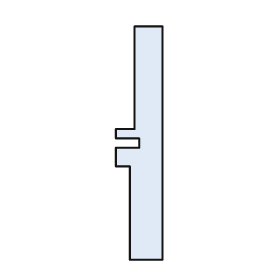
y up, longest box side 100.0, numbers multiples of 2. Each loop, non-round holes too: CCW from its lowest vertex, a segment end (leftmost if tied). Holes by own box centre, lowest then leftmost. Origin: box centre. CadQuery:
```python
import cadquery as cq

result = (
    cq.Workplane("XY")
    .moveTo(-4.0, -50.0)
    .lineTo(10.0, -50.0)
    .lineTo(10.0, 50.0)
    .lineTo(-2.0, 50.0)
    .lineTo(-2.0, 6.0)
    .lineTo(-10.0, 6.0)
    .lineTo(-10.0, 2.0)
    .lineTo(0.0, 2.0)
    .lineTo(0.0, -2.0)
    .lineTo(-10.0, -2.0)
    .lineTo(-10.0, -10.0)
    .lineTo(-4.0, -10.0)
    .close()
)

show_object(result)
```